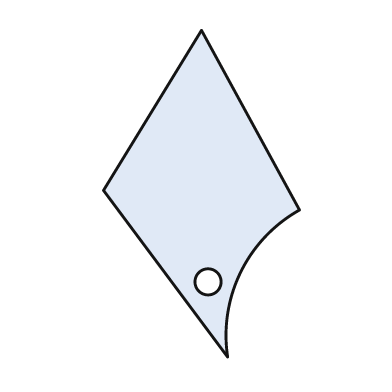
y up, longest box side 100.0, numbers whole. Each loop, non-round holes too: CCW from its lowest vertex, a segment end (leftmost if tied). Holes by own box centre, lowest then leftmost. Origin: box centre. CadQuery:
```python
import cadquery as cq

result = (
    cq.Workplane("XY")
    .moveTo(8.0, -50.0)
    .threePointArc((12.0, -24.0), (30.0, -5.0))
    .lineTo(0.0, 50.0)
    .lineTo(-30.0, 1.0)
    .close()
    .moveTo(2.0, -27.0)
    .circle(4.0)
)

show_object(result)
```